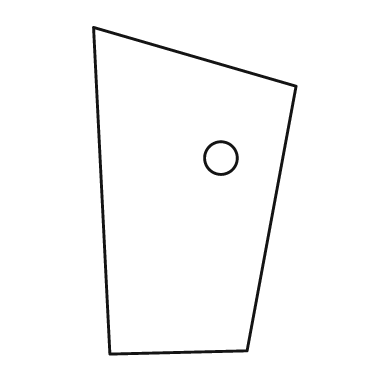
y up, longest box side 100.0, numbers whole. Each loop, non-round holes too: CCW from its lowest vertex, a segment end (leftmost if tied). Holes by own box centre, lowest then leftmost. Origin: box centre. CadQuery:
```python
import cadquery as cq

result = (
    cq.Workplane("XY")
    .moveTo(-26.0, -50.0)
    .lineTo(16.0, -49.0)
    .lineTo(31.0, 32.0)
    .lineTo(-31.0, 50.0)
    .close()
    .moveTo(8.0, 10.0)
    .circle(5.0)
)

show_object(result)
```